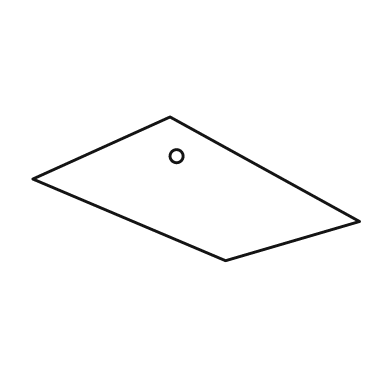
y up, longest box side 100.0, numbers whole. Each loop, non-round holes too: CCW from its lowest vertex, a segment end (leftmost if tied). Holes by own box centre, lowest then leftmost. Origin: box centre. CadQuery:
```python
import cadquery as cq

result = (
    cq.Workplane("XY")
    .moveTo(9.0, -22.0)
    .lineTo(50.0, -10.0)
    .lineTo(-8.0, 22.0)
    .lineTo(-50.0, 3.0)
    .close()
    .moveTo(-6.0, 10.0)
    .circle(2.0)
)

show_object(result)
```